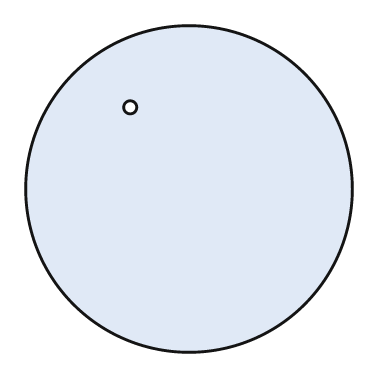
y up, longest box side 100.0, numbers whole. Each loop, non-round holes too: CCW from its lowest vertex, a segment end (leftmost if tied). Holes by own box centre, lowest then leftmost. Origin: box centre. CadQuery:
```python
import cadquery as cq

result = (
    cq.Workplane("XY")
    .moveTo(0.0, 0.0)
    .circle(50.0)
    .moveTo(-18.0, 25.0)
    .circle(2.0)
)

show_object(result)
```